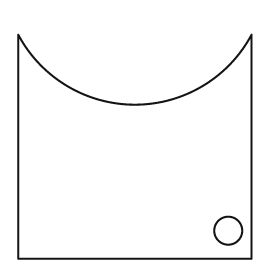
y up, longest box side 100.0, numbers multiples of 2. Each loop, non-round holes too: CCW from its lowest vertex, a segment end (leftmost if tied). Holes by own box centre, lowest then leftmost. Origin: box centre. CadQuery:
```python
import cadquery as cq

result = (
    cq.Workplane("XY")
    .moveTo(-50.0, -48.0)
    .lineTo(50.0, -48.0)
    .lineTo(50.0, 48.0)
    .threePointArc((0.0, 18.0), (-50.0, 48.0))
    .close()
    .moveTo(40.0, -36.0)
    .circle(6.0)
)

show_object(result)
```